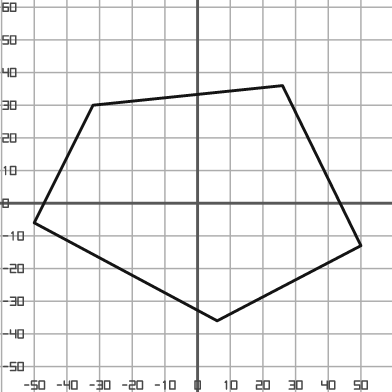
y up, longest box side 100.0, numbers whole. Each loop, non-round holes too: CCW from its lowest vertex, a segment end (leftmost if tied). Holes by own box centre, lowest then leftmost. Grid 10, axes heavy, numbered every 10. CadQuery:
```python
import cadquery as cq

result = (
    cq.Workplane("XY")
    .moveTo(6.0, -36.0)
    .lineTo(50.0, -13.0)
    .lineTo(26.0, 36.0)
    .lineTo(-32.0, 30.0)
    .lineTo(-50.0, -6.0)
    .close()
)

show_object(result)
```